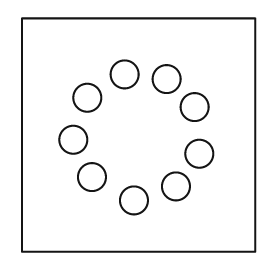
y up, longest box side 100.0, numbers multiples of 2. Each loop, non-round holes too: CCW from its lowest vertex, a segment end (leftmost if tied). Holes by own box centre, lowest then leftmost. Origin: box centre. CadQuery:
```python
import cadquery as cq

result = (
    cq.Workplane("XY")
    .moveTo(-50.0, -50.0)
    .lineTo(50.0, -50.0)
    .lineTo(50.0, 50.0)
    .lineTo(-50.0, 50.0)
    .close()
    .moveTo(-2.0, -28.0)
    .circle(6.0)
    .moveTo(16.0, -22.0)
    .circle(6.0)
    .moveTo(-20.0, -18.0)
    .circle(6.0)
    .moveTo(26.0, -8.0)
    .circle(6.0)
    .moveTo(-28.0, -2.0)
    .circle(6.0)
    .moveTo(24.0, 12.0)
    .circle(6.0)
    .moveTo(-22.0, 16.0)
    .circle(6.0)
    .moveTo(12.0, 24.0)
    .circle(6.0)
    .moveTo(-6.0, 26.0)
    .circle(6.0)
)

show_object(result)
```